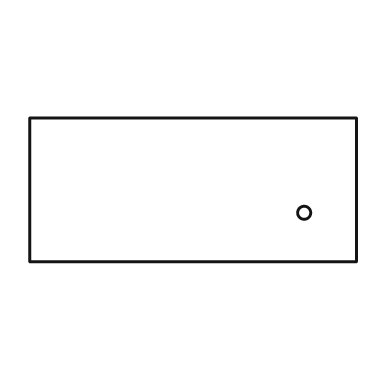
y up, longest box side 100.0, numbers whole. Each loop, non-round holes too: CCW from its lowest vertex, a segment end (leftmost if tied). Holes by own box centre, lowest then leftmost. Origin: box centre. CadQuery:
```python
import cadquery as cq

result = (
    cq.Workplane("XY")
    .moveTo(-50.0, -22.0)
    .lineTo(50.0, -22.0)
    .lineTo(50.0, 22.0)
    .lineTo(-50.0, 22.0)
    .close()
    .moveTo(34.0, -7.0)
    .circle(2.0)
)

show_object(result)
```